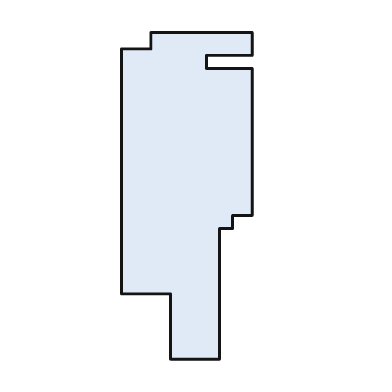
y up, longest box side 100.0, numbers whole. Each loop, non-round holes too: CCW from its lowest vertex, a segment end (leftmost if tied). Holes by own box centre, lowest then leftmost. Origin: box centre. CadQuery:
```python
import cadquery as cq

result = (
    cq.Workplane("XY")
    .moveTo(-5.0, -50.0)
    .lineTo(10.0, -50.0)
    .lineTo(10.0, -10.0)
    .lineTo(14.0, -10.0)
    .lineTo(14.0, -6.0)
    .lineTo(20.0, -6.0)
    .lineTo(20.0, 39.0)
    .lineTo(6.0, 39.0)
    .lineTo(6.0, 43.0)
    .lineTo(20.0, 43.0)
    .lineTo(20.0, 50.0)
    .lineTo(-11.0, 50.0)
    .lineTo(-11.0, 45.0)
    .lineTo(-20.0, 45.0)
    .lineTo(-20.0, -30.0)
    .lineTo(-5.0, -30.0)
    .close()
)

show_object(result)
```